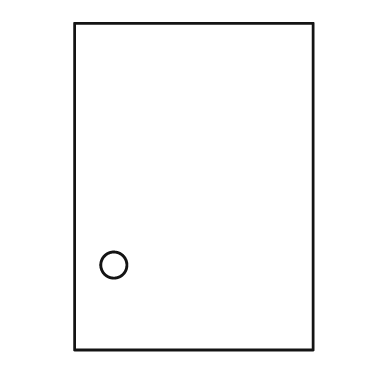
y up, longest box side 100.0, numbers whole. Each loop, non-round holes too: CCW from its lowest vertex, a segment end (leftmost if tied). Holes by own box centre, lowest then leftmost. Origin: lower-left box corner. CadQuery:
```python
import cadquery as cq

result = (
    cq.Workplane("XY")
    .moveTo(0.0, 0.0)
    .lineTo(73.0, 0.0)
    .lineTo(73.0, 100.0)
    .lineTo(0.0, 100.0)
    .close()
    .moveTo(12.0, 26.0)
    .circle(4.0)
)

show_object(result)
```